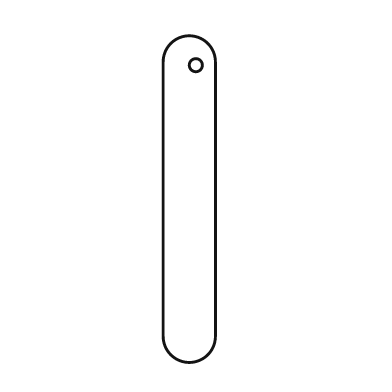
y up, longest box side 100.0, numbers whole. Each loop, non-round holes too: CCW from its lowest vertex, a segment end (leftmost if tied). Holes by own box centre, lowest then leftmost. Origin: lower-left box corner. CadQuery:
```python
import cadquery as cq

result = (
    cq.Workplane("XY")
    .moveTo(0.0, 8.0)
    .threePointArc((8.0, 0.0), (16.0, 8.0))
    .lineTo(16.0, 92.0)
    .threePointArc((8.0, 100.0), (0.0, 92.0))
    .close()
    .moveTo(10.0, 91.0)
    .circle(2.0)
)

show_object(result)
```